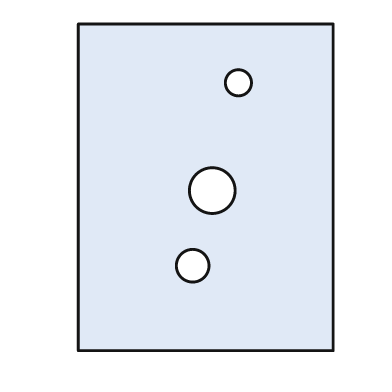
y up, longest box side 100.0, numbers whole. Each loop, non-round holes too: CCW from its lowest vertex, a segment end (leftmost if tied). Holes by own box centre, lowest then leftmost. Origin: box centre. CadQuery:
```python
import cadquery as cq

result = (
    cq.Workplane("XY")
    .moveTo(-39.0, -50.0)
    .lineTo(39.0, -50.0)
    .lineTo(39.0, 50.0)
    .lineTo(-39.0, 50.0)
    .close()
    .moveTo(-4.0, -24.0)
    .circle(5.0)
    .moveTo(2.0, -1.0)
    .circle(7.0)
    .moveTo(10.0, 32.0)
    .circle(4.0)
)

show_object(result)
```